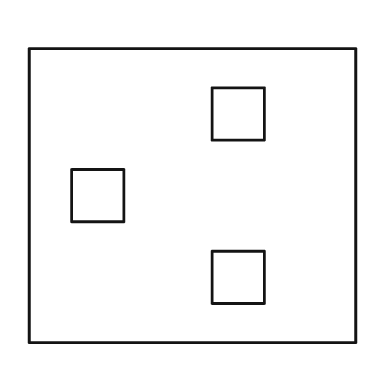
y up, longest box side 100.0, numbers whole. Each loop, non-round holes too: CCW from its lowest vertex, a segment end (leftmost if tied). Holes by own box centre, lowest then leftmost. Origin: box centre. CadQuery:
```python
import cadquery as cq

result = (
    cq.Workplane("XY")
    .moveTo(-50.0, -45.0)
    .lineTo(50.0, -45.0)
    .lineTo(50.0, 45.0)
    .lineTo(-50.0, 45.0)
    .close()
    .moveTo(6.0, -33.0)
    .lineTo(22.0, -33.0)
    .lineTo(22.0, -17.0)
    .lineTo(6.0, -17.0)
    .close()
    .moveTo(-37.0, -8.0)
    .lineTo(-21.0, -8.0)
    .lineTo(-21.0, 8.0)
    .lineTo(-37.0, 8.0)
    .close()
    .moveTo(6.0, 17.0)
    .lineTo(22.0, 17.0)
    .lineTo(22.0, 33.0)
    .lineTo(6.0, 33.0)
    .close()
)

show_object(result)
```